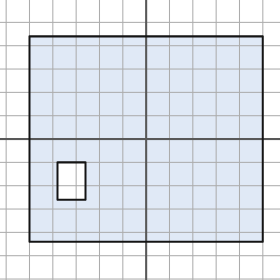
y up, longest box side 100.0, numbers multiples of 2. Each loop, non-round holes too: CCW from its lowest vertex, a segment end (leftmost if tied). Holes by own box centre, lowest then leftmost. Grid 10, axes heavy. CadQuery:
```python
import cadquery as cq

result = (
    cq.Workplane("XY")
    .moveTo(-50.0, -44.0)
    .lineTo(50.0, -44.0)
    .lineTo(50.0, 44.0)
    .lineTo(-50.0, 44.0)
    .close()
    .moveTo(-38.0, -26.0)
    .lineTo(-26.0, -26.0)
    .lineTo(-26.0, -10.0)
    .lineTo(-38.0, -10.0)
    .close()
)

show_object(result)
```